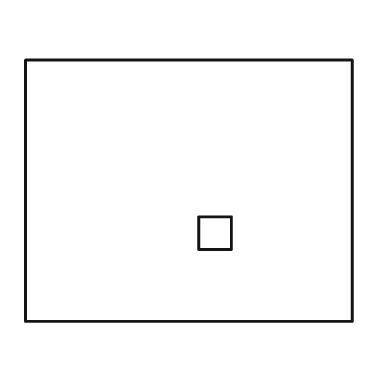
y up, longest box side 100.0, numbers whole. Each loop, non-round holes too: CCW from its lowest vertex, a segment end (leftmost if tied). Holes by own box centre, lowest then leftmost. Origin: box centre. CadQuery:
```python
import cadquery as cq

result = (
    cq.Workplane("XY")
    .moveTo(-50.0, -40.0)
    .lineTo(50.0, -40.0)
    .lineTo(50.0, 40.0)
    .lineTo(-50.0, 40.0)
    .close()
    .moveTo(3.0, -18.0)
    .lineTo(13.0, -18.0)
    .lineTo(13.0, -8.0)
    .lineTo(3.0, -8.0)
    .close()
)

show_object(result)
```